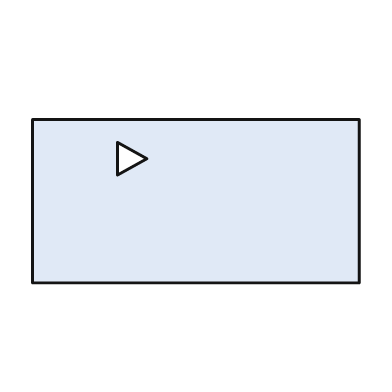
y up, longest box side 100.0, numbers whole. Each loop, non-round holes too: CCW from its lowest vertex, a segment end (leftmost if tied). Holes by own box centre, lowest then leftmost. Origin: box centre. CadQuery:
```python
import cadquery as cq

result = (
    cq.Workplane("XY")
    .moveTo(-50.0, -25.0)
    .lineTo(50.0, -25.0)
    .lineTo(50.0, 25.0)
    .lineTo(-50.0, 25.0)
    .close()
    .moveTo(-24.0, 8.0)
    .lineTo(-15.0, 13.0)
    .lineTo(-24.0, 18.0)
    .close()
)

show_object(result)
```